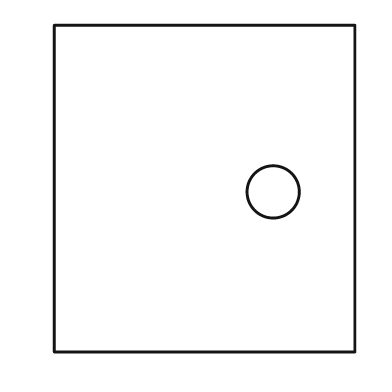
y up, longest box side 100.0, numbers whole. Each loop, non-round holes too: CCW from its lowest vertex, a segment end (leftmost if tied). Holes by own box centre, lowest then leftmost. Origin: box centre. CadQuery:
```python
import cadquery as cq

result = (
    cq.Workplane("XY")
    .moveTo(-46.0, -50.0)
    .lineTo(46.0, -50.0)
    .lineTo(46.0, 50.0)
    .lineTo(-46.0, 50.0)
    .close()
    .moveTo(21.0, -1.0)
    .circle(8.0)
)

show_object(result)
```